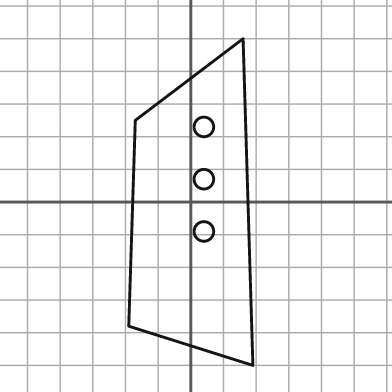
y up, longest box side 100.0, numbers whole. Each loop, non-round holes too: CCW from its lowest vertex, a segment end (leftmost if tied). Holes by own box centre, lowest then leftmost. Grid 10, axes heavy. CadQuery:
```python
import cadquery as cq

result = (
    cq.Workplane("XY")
    .moveTo(19.0, -50.0)
    .lineTo(16.0, 50.0)
    .lineTo(-17.0, 25.0)
    .lineTo(-19.0, -38.0)
    .close()
    .moveTo(4.0, -9.0)
    .circle(3.0)
    .moveTo(4.0, 7.0)
    .circle(3.0)
    .moveTo(4.0, 23.0)
    .circle(3.0)
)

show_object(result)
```